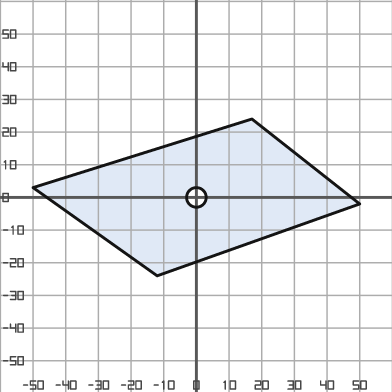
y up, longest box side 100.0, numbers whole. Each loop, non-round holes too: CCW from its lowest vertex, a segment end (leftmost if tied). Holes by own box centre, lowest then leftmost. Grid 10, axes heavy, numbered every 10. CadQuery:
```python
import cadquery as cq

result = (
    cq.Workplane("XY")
    .moveTo(-12.0, -24.0)
    .lineTo(50.0, -2.0)
    .lineTo(17.0, 24.0)
    .lineTo(-50.0, 3.0)
    .close()
    .moveTo(0.0, 0.0)
    .circle(3.0)
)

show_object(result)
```